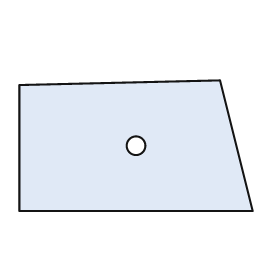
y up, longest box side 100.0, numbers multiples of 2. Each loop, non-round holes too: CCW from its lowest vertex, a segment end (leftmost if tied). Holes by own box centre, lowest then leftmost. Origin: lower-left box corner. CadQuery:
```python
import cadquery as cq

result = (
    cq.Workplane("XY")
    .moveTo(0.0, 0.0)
    .lineTo(100.0, 0.0)
    .lineTo(86.0, 56.0)
    .lineTo(0.0, 54.0)
    .close()
    .moveTo(50.0, 28.0)
    .circle(4.0)
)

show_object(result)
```